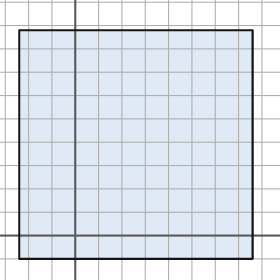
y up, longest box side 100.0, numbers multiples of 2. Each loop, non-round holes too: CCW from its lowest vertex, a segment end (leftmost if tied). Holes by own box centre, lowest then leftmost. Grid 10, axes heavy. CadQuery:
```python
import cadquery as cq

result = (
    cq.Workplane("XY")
    .moveTo(-24.0, -10.0)
    .lineTo(76.0, -10.0)
    .lineTo(76.0, 88.0)
    .lineTo(-24.0, 88.0)
    .close()
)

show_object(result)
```